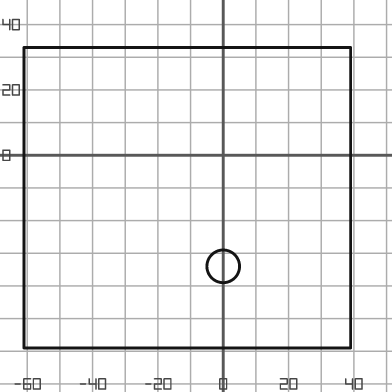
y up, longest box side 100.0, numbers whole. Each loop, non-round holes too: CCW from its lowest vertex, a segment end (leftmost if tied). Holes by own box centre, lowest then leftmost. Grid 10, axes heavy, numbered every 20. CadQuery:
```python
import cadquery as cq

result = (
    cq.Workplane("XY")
    .moveTo(-61.0, -59.0)
    .lineTo(39.0, -59.0)
    .lineTo(39.0, 33.0)
    .lineTo(-61.0, 33.0)
    .close()
    .moveTo(0.0, -34.0)
    .circle(5.0)
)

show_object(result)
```